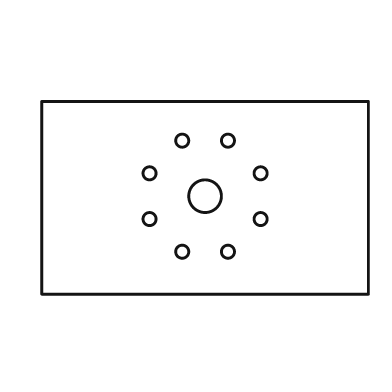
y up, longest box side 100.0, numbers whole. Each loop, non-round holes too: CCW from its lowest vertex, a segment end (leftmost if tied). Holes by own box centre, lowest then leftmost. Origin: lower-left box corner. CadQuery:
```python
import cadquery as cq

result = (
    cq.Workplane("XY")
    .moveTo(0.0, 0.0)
    .lineTo(100.0, 0.0)
    .lineTo(100.0, 59.0)
    .lineTo(0.0, 59.0)
    .close()
    .moveTo(43.0, 13.0)
    .circle(2.0)
    .moveTo(57.0, 13.0)
    .circle(2.0)
    .moveTo(33.0, 23.0)
    .circle(2.0)
    .moveTo(67.0, 23.0)
    .circle(2.0)
    .moveTo(50.0, 30.0)
    .circle(5.0)
    .moveTo(33.0, 37.0)
    .circle(2.0)
    .moveTo(67.0, 37.0)
    .circle(2.0)
    .moveTo(43.0, 47.0)
    .circle(2.0)
    .moveTo(57.0, 47.0)
    .circle(2.0)
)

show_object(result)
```